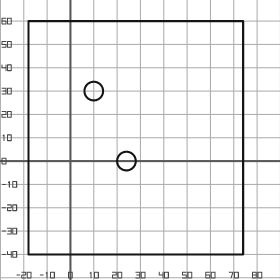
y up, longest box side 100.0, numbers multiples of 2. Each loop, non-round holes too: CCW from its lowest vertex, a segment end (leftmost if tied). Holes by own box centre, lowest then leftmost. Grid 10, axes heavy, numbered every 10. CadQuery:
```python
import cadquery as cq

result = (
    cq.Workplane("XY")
    .moveTo(-18.0, -40.0)
    .lineTo(74.0, -40.0)
    .lineTo(74.0, 60.0)
    .lineTo(-18.0, 60.0)
    .close()
    .moveTo(24.0, 0.0)
    .circle(4.0)
    .moveTo(10.0, 30.0)
    .circle(4.0)
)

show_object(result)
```